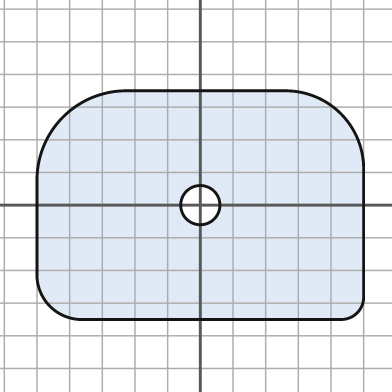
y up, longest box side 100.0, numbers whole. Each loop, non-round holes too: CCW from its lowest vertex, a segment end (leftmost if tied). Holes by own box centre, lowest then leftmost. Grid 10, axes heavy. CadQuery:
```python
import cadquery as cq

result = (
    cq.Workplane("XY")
    .moveTo(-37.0, -35.0)
    .lineTo(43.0, -35.0)
    .threePointArc((48.0, -33.0), (50.0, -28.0))
    .lineTo(50.0, 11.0)
    .threePointArc((43.0, 28.0), (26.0, 35.0))
    .lineTo(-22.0, 35.0)
    .threePointArc((-42.0, 27.0), (-50.0, 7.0))
    .lineTo(-50.0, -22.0)
    .threePointArc((-46.0, -31.0), (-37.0, -35.0))
    .close()
    .moveTo(0.0, 0.0)
    .circle(6.0)
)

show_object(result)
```